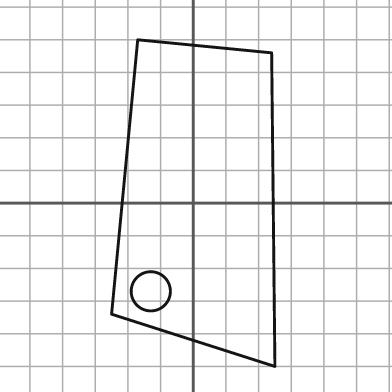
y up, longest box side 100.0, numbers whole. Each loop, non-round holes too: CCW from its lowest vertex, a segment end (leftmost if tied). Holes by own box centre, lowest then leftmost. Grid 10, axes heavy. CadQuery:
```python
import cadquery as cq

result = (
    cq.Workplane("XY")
    .moveTo(25.0, -50.0)
    .lineTo(24.0, 46.0)
    .lineTo(-17.0, 50.0)
    .lineTo(-25.0, -34.0)
    .close()
    .moveTo(-13.0, -27.0)
    .circle(6.0)
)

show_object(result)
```